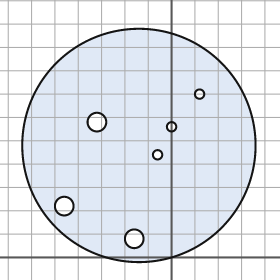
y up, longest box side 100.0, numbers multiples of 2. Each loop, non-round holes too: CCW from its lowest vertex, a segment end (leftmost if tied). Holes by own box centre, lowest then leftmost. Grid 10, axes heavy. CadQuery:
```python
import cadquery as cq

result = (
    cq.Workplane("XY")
    .moveTo(-14.0, 48.0)
    .circle(50.0)
    .moveTo(-16.0, 8.0)
    .circle(4.0)
    .moveTo(-46.0, 22.0)
    .circle(4.0)
    .moveTo(-6.0, 44.0)
    .circle(2.0)
    .moveTo(0.0, 56.0)
    .circle(2.0)
    .moveTo(-32.0, 58.0)
    .circle(4.0)
    .moveTo(12.0, 70.0)
    .circle(2.0)
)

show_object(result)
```